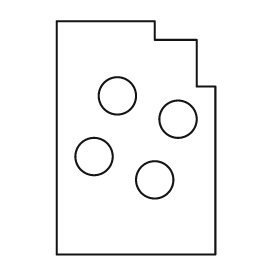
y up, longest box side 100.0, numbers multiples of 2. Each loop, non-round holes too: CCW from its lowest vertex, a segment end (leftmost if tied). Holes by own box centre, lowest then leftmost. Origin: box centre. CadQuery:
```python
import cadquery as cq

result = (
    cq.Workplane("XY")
    .moveTo(-34.0, -50.0)
    .lineTo(34.0, -50.0)
    .lineTo(34.0, 22.0)
    .lineTo(26.0, 22.0)
    .lineTo(26.0, 42.0)
    .lineTo(8.0, 42.0)
    .lineTo(8.0, 50.0)
    .lineTo(-34.0, 50.0)
    .close()
    .moveTo(8.0, -18.0)
    .circle(8.0)
    .moveTo(-18.0, -8.0)
    .circle(8.0)
    .moveTo(18.0, 8.0)
    .circle(8.0)
    .moveTo(-8.0, 18.0)
    .circle(8.0)
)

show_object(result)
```